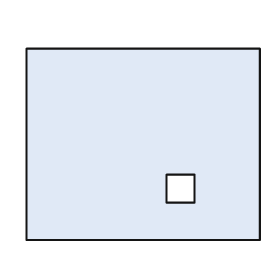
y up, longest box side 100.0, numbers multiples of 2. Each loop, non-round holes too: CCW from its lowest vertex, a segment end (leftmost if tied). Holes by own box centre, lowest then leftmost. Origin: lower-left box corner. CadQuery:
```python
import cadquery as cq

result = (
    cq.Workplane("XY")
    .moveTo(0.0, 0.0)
    .lineTo(100.0, 0.0)
    .lineTo(100.0, 82.0)
    .lineTo(0.0, 82.0)
    .close()
    .moveTo(60.0, 16.0)
    .lineTo(72.0, 16.0)
    .lineTo(72.0, 28.0)
    .lineTo(60.0, 28.0)
    .close()
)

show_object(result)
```